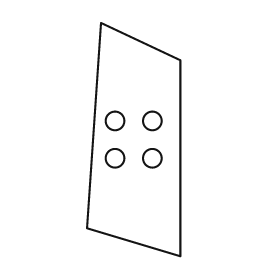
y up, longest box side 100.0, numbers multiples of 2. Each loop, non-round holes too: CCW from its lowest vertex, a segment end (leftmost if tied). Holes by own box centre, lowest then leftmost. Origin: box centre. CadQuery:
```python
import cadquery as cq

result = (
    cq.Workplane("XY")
    .moveTo(20.0, -50.0)
    .lineTo(20.0, 34.0)
    .lineTo(-14.0, 50.0)
    .lineTo(-20.0, -38.0)
    .close()
    .moveTo(-8.0, -8.0)
    .circle(4.0)
    .moveTo(8.0, -8.0)
    .circle(4.0)
    .moveTo(-8.0, 8.0)
    .circle(4.0)
    .moveTo(8.0, 8.0)
    .circle(4.0)
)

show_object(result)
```